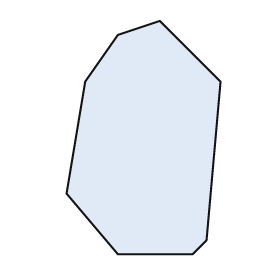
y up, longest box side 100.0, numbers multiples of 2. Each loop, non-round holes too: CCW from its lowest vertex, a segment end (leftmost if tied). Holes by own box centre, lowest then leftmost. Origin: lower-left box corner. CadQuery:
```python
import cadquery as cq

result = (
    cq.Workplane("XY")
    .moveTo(22.0, 0.0)
    .lineTo(54.0, 0.0)
    .lineTo(60.0, 6.0)
    .lineTo(66.0, 74.0)
    .lineTo(40.0, 100.0)
    .lineTo(22.0, 94.0)
    .lineTo(8.0, 74.0)
    .lineTo(0.0, 26.0)
    .close()
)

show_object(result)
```